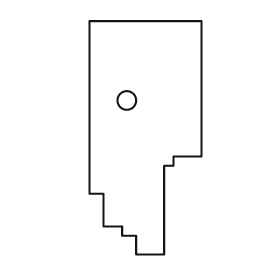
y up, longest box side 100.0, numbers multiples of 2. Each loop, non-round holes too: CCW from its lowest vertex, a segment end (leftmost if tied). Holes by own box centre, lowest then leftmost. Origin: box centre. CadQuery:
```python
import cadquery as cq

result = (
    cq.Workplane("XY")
    .moveTo(-4.0, -50.0)
    .lineTo(8.0, -50.0)
    .lineTo(8.0, -12.0)
    .lineTo(12.0, -12.0)
    .lineTo(12.0, -8.0)
    .lineTo(24.0, -8.0)
    .lineTo(24.0, 50.0)
    .lineTo(-24.0, 50.0)
    .lineTo(-24.0, -24.0)
    .lineTo(-18.0, -24.0)
    .lineTo(-18.0, -38.0)
    .lineTo(-10.0, -38.0)
    .lineTo(-10.0, -42.0)
    .lineTo(-4.0, -42.0)
    .close()
    .moveTo(-8.0, 16.0)
    .circle(4.0)
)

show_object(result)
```